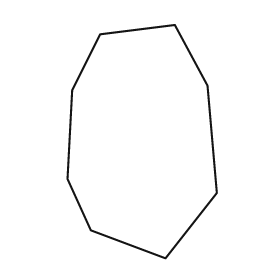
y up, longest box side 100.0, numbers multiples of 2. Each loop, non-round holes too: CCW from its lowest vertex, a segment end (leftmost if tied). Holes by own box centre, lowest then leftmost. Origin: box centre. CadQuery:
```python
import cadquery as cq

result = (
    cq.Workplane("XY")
    .moveTo(10.0, -50.0)
    .lineTo(32.0, -22.0)
    .lineTo(28.0, 24.0)
    .lineTo(14.0, 50.0)
    .lineTo(-18.0, 46.0)
    .lineTo(-30.0, 22.0)
    .lineTo(-32.0, -16.0)
    .lineTo(-22.0, -38.0)
    .close()
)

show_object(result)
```